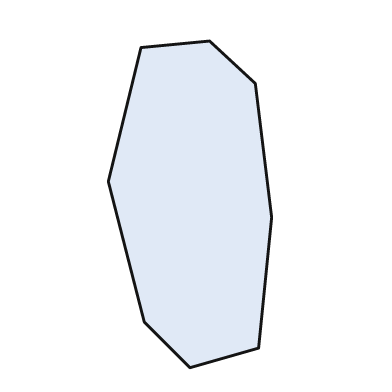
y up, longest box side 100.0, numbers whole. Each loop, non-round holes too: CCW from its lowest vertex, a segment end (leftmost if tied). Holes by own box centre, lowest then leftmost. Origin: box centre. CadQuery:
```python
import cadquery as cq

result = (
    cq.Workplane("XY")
    .moveTo(0.0, -50.0)
    .lineTo(21.0, -44.0)
    .lineTo(25.0, -4.0)
    .lineTo(20.0, 37.0)
    .lineTo(6.0, 50.0)
    .lineTo(-15.0, 48.0)
    .lineTo(-25.0, 7.0)
    .lineTo(-14.0, -36.0)
    .close()
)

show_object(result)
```